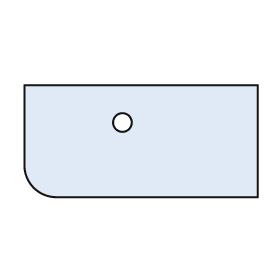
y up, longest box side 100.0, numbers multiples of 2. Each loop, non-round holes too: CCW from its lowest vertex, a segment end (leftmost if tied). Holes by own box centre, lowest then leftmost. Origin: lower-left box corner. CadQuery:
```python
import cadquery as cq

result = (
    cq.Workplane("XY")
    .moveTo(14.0, 0.0)
    .lineTo(100.0, 0.0)
    .lineTo(100.0, 48.0)
    .lineTo(0.0, 48.0)
    .lineTo(0.0, 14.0)
    .threePointArc((4.0, 4.0), (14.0, 0.0))
    .close()
    .moveTo(42.0, 32.0)
    .circle(4.0)
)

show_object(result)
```